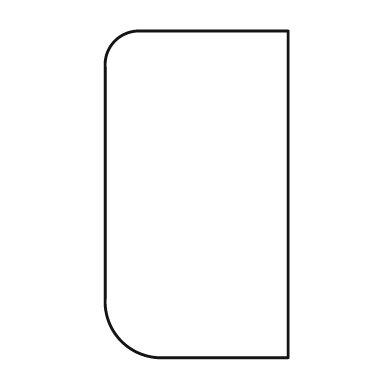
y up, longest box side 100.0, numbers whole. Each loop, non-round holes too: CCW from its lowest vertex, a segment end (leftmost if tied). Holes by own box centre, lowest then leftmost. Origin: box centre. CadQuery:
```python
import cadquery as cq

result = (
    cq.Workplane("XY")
    .moveTo(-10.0, -50.0)
    .lineTo(28.0, -50.0)
    .lineTo(28.0, 50.0)
    .lineTo(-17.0, 50.0)
    .threePointArc((-25.0, 47.0), (-28.0, 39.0))
    .lineTo(-28.0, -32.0)
    .threePointArc((-23.0, -45.0), (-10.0, -50.0))
    .close()
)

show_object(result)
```